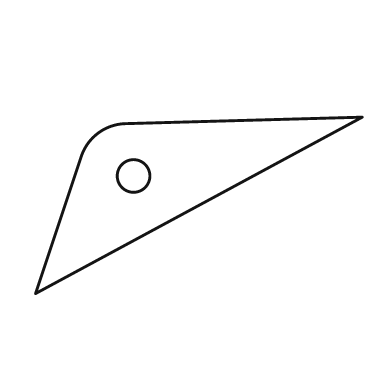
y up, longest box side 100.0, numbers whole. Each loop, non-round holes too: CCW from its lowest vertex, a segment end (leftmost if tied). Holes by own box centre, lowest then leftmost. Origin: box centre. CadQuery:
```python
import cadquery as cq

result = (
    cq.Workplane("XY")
    .moveTo(-50.0, -27.0)
    .lineTo(50.0, 27.0)
    .lineTo(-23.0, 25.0)
    .threePointArc((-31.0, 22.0), (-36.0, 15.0))
    .close()
    .moveTo(-20.0, 9.0)
    .circle(5.0)
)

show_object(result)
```